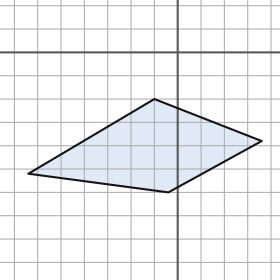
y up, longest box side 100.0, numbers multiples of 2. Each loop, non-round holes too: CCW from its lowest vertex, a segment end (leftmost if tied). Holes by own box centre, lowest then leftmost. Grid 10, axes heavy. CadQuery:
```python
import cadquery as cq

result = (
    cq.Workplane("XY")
    .moveTo(-4.0, -60.0)
    .lineTo(36.0, -38.0)
    .lineTo(-10.0, -20.0)
    .lineTo(-64.0, -52.0)
    .close()
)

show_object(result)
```